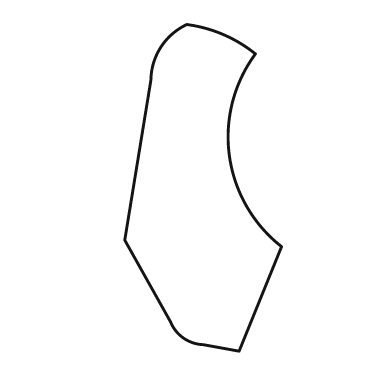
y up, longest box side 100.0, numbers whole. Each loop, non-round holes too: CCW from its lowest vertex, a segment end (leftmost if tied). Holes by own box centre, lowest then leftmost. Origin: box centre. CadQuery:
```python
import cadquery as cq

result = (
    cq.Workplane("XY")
    .moveTo(11.0, -50.0)
    .lineTo(24.0, -18.0)
    .threePointArc((8.0, 10.0), (16.0, 41.0))
    .threePointArc((6.0, 47.0), (-5.0, 50.0))
    .threePointArc((-13.0, 43.0), (-16.0, 33.0))
    .lineTo(-24.0, -16.0)
    .lineTo(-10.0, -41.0)
    .threePointArc((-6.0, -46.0), (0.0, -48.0))
    .close()
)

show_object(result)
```